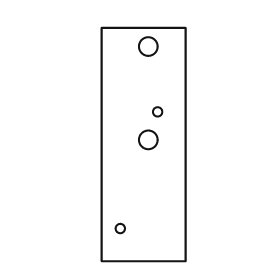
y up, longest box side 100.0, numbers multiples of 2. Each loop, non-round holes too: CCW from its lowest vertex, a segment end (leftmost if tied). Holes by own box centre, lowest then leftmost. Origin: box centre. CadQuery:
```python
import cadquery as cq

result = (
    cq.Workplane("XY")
    .moveTo(-18.0, -50.0)
    .lineTo(18.0, -50.0)
    .lineTo(18.0, 50.0)
    .lineTo(-18.0, 50.0)
    .close()
    .moveTo(-10.0, -36.0)
    .circle(2.0)
    .moveTo(2.0, 2.0)
    .circle(4.0)
    .moveTo(6.0, 14.0)
    .circle(2.0)
    .moveTo(2.0, 42.0)
    .circle(4.0)
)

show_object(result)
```